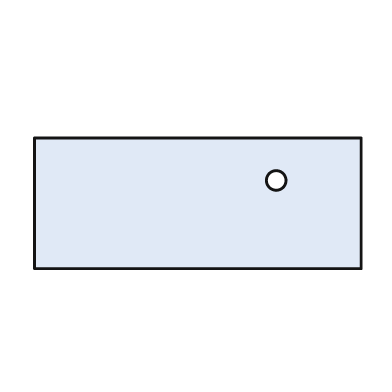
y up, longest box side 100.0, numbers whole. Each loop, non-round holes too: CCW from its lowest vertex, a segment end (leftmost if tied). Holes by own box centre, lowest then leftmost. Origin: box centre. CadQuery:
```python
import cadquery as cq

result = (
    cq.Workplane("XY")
    .moveTo(-50.0, -20.0)
    .lineTo(50.0, -20.0)
    .lineTo(50.0, 20.0)
    .lineTo(-50.0, 20.0)
    .close()
    .moveTo(24.0, 7.0)
    .circle(3.0)
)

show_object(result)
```